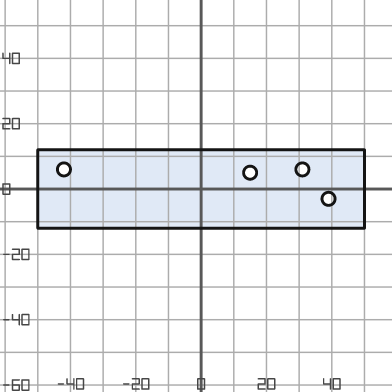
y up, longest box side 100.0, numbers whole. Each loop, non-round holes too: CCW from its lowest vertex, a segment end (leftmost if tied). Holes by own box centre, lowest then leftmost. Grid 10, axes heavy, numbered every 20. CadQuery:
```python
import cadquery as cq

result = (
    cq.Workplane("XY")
    .moveTo(-50.0, -12.0)
    .lineTo(50.0, -12.0)
    .lineTo(50.0, 12.0)
    .lineTo(-50.0, 12.0)
    .close()
    .moveTo(39.0, -3.0)
    .circle(2.0)
    .moveTo(15.0, 5.0)
    .circle(2.0)
    .moveTo(-42.0, 6.0)
    .circle(2.0)
    .moveTo(31.0, 6.0)
    .circle(2.0)
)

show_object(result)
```